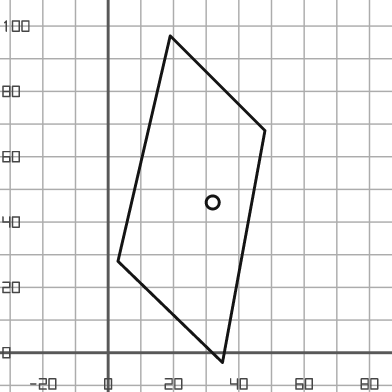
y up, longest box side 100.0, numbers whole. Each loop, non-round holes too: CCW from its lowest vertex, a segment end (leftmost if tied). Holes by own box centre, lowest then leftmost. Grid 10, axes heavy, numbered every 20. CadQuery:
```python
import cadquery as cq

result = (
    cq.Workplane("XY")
    .moveTo(35.0, -3.0)
    .lineTo(48.0, 68.0)
    .lineTo(19.0, 97.0)
    .lineTo(3.0, 28.0)
    .close()
    .moveTo(32.0, 46.0)
    .circle(2.0)
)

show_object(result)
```